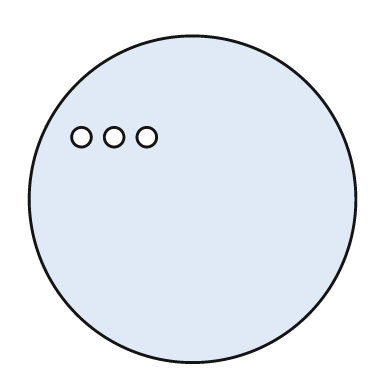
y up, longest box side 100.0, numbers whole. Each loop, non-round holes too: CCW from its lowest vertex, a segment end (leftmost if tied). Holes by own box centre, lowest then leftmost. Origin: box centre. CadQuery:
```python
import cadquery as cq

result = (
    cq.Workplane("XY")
    .moveTo(0.0, 0.0)
    .circle(50.0)
    .moveTo(-34.0, 19.0)
    .circle(3.0)
    .moveTo(-24.0, 19.0)
    .circle(3.0)
    .moveTo(-14.0, 19.0)
    .circle(3.0)
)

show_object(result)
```